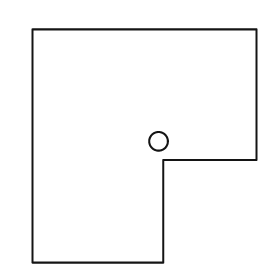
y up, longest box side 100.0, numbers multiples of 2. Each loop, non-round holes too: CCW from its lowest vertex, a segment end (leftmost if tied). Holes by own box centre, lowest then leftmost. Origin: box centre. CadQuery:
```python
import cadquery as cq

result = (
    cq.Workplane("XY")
    .moveTo(-48.0, -50.0)
    .lineTo(8.0, -50.0)
    .lineTo(8.0, -6.0)
    .lineTo(48.0, -6.0)
    .lineTo(48.0, 50.0)
    .lineTo(-48.0, 50.0)
    .close()
    .moveTo(6.0, 2.0)
    .circle(4.0)
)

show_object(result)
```